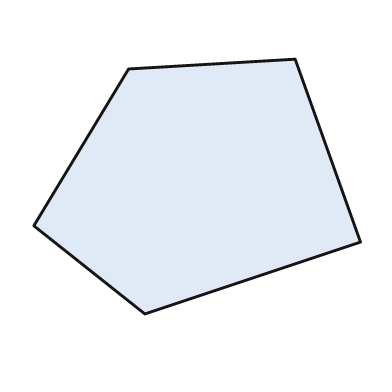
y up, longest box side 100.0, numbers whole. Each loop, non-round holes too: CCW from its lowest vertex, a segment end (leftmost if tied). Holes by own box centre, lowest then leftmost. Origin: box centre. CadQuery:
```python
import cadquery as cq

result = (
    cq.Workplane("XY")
    .moveTo(-16.0, -39.0)
    .lineTo(50.0, -17.0)
    .lineTo(30.0, 39.0)
    .lineTo(-21.0, 36.0)
    .lineTo(-50.0, -12.0)
    .close()
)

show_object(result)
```